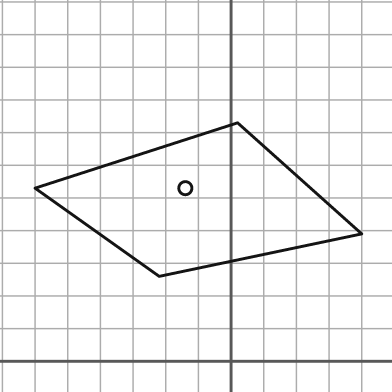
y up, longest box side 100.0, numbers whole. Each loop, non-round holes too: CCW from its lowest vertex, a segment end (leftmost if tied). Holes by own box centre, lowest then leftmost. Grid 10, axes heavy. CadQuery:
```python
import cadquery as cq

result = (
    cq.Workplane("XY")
    .moveTo(-22.0, 26.0)
    .lineTo(40.0, 39.0)
    .lineTo(2.0, 73.0)
    .lineTo(-60.0, 53.0)
    .close()
    .moveTo(-14.0, 53.0)
    .circle(2.0)
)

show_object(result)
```